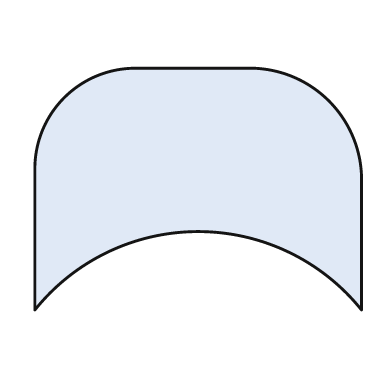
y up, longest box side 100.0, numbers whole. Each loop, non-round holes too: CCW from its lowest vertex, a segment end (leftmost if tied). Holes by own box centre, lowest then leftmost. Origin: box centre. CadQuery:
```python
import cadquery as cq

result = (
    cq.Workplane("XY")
    .moveTo(-50.0, -37.0)
    .threePointArc((0.0, -13.0), (50.0, -37.0))
    .lineTo(50.0, 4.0)
    .threePointArc((40.0, 27.0), (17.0, 37.0))
    .lineTo(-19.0, 37.0)
    .threePointArc((-41.0, 28.0), (-50.0, 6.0))
    .close()
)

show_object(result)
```